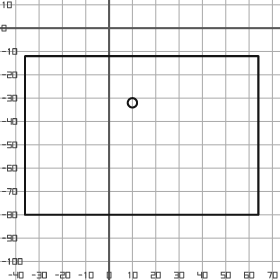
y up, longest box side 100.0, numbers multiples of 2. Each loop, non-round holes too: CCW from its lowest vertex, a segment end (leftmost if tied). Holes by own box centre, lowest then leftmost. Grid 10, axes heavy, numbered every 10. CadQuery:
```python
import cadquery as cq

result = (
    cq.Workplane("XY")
    .moveTo(-36.0, -80.0)
    .lineTo(64.0, -80.0)
    .lineTo(64.0, -12.0)
    .lineTo(-36.0, -12.0)
    .close()
    .moveTo(10.0, -32.0)
    .circle(2.0)
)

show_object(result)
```